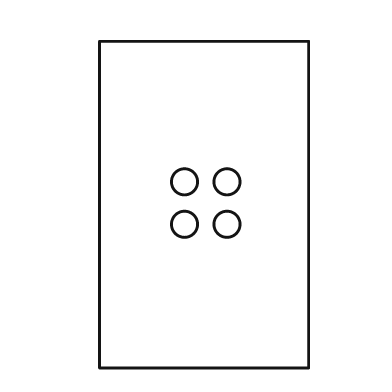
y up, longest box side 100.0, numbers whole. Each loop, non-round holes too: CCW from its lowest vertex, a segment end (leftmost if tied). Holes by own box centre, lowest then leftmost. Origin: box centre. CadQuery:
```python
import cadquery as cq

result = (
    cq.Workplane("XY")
    .moveTo(-32.0, -50.0)
    .lineTo(32.0, -50.0)
    .lineTo(32.0, 50.0)
    .lineTo(-32.0, 50.0)
    .close()
    .moveTo(-6.0, -6.0)
    .circle(4.0)
    .moveTo(7.0, -6.0)
    .circle(4.0)
    .moveTo(-6.0, 7.0)
    .circle(4.0)
    .moveTo(7.0, 7.0)
    .circle(4.0)
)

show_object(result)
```